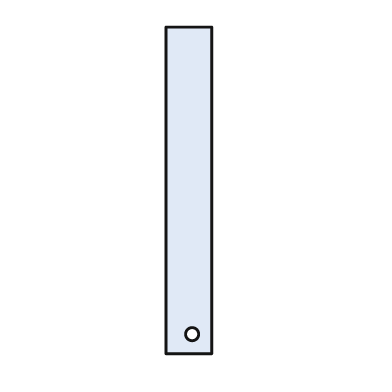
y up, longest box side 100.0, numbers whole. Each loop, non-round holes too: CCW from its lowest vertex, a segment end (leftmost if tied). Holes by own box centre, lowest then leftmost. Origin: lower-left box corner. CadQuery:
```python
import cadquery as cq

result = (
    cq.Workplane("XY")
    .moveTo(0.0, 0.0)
    .lineTo(14.0, 0.0)
    .lineTo(14.0, 100.0)
    .lineTo(0.0, 100.0)
    .close()
    .moveTo(8.0, 6.0)
    .circle(2.0)
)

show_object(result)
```